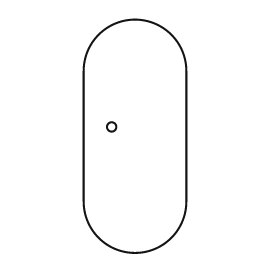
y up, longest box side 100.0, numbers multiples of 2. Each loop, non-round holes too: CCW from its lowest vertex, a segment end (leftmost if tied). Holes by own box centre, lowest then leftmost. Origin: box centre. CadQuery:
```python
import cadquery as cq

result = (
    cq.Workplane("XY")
    .moveTo(-22.0, -28.0)
    .threePointArc((0.0, -50.0), (22.0, -28.0))
    .lineTo(22.0, 28.0)
    .threePointArc((0.0, 50.0), (-22.0, 28.0))
    .close()
    .moveTo(-10.0, 4.0)
    .circle(2.0)
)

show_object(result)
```